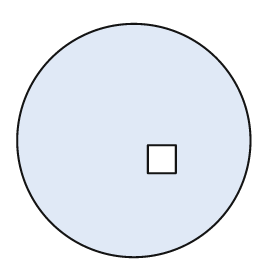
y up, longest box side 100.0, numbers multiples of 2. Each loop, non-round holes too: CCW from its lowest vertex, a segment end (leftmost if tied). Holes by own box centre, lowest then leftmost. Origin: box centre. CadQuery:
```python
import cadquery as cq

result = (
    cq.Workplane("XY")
    .moveTo(0.0, 0.0)
    .circle(50.0)
    .moveTo(6.0, -14.0)
    .lineTo(18.0, -14.0)
    .lineTo(18.0, -2.0)
    .lineTo(6.0, -2.0)
    .close()
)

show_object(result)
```